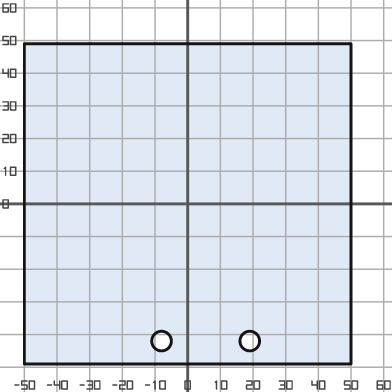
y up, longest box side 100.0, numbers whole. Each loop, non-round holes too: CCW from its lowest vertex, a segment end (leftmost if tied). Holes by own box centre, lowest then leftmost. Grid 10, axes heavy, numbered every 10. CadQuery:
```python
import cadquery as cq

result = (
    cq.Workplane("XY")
    .moveTo(-50.0, -49.0)
    .lineTo(50.0, -49.0)
    .lineTo(50.0, 49.0)
    .lineTo(-50.0, 49.0)
    .close()
    .moveTo(-8.0, -42.0)
    .circle(3.0)
    .moveTo(19.0, -42.0)
    .circle(3.0)
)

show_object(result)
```